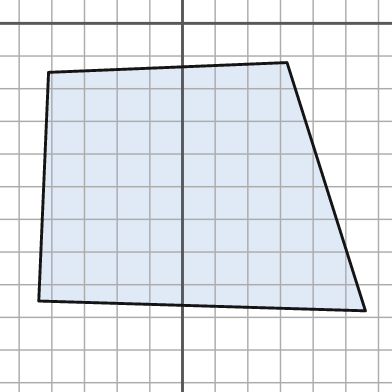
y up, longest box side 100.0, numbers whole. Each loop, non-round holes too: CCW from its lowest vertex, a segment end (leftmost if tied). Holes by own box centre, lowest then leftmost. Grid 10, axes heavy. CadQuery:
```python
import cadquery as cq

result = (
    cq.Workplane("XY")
    .moveTo(56.0, -88.0)
    .lineTo(32.0, -12.0)
    .lineTo(-41.0, -15.0)
    .lineTo(-44.0, -85.0)
    .close()
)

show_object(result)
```